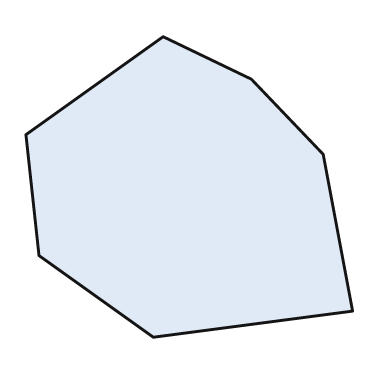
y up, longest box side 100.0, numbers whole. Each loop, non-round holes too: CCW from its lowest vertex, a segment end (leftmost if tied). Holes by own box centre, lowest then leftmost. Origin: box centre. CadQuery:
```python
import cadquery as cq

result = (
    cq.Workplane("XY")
    .moveTo(-11.0, -46.0)
    .lineTo(50.0, -38.0)
    .lineTo(41.0, 10.0)
    .lineTo(19.0, 33.0)
    .lineTo(-8.0, 46.0)
    .lineTo(-50.0, 16.0)
    .lineTo(-46.0, -21.0)
    .close()
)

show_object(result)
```